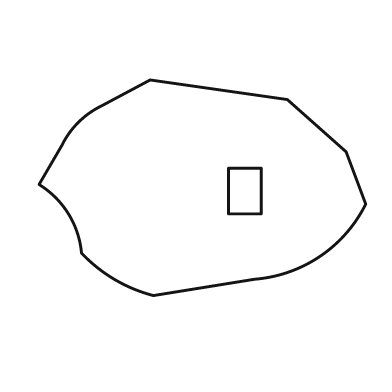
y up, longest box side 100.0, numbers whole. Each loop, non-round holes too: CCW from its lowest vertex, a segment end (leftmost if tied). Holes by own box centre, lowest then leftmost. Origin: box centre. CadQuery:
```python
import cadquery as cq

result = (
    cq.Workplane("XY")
    .moveTo(-15.0, -33.0)
    .lineTo(16.0, -28.0)
    .threePointArc((36.0, -21.0), (50.0, -5.0))
    .lineTo(44.0, 11.0)
    .lineTo(26.0, 27.0)
    .lineTo(-16.0, 33.0)
    .lineTo(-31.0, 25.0)
    .threePointArc((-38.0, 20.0), (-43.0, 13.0))
    .lineTo(-50.0, 1.0)
    .threePointArc((-41.0, -8.0), (-37.0, -20.0))
    .threePointArc((-27.0, -28.0), (-15.0, -33.0))
    .close()
    .moveTo(8.0, -8.0)
    .lineTo(18.0, -8.0)
    .lineTo(18.0, 6.0)
    .lineTo(8.0, 6.0)
    .close()
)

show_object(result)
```